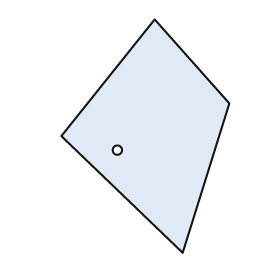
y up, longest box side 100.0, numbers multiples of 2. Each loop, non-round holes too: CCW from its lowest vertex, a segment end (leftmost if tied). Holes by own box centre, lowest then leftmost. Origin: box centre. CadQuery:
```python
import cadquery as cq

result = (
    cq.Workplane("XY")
    .moveTo(16.0, -50.0)
    .lineTo(36.0, 14.0)
    .lineTo(4.0, 50.0)
    .lineTo(-36.0, 0.0)
    .close()
    .moveTo(-12.0, -6.0)
    .circle(2.0)
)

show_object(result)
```